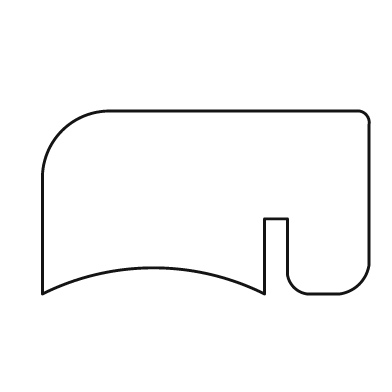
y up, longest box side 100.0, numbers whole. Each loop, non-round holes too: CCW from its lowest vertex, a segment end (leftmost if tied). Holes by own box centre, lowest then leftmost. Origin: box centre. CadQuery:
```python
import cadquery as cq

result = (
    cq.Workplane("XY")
    .moveTo(-50.0, -28.0)
    .threePointArc((-16.0, -20.0), (18.0, -28.0))
    .lineTo(18.0, -5.0)
    .lineTo(25.0, -5.0)
    .lineTo(25.0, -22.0)
    .threePointArc((27.0, -26.0), (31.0, -28.0))
    .lineTo(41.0, -28.0)
    .threePointArc((47.0, -25.0), (50.0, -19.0))
    .lineTo(50.0, 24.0)
    .threePointArc((49.0, 27.0), (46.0, 28.0))
    .lineTo(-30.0, 28.0)
    .threePointArc((-44.0, 22.0), (-50.0, 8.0))
    .close()
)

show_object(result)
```